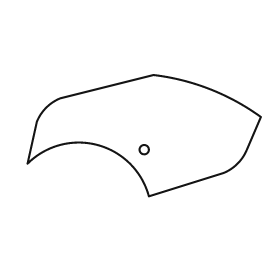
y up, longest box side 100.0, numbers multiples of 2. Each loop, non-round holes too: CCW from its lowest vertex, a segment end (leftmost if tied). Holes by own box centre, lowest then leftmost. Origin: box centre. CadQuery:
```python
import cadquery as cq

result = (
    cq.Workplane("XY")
    .moveTo(2.0, -26.0)
    .lineTo(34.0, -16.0)
    .threePointArc((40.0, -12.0), (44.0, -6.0))
    .lineTo(50.0, 8.0)
    .threePointArc((28.0, 20.0), (4.0, 26.0))
    .lineTo(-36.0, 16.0)
    .threePointArc((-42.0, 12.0), (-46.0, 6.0))
    .lineTo(-50.0, -12.0)
    .threePointArc((-20.0, -4.0), (2.0, -26.0))
    .close()
    .moveTo(0.0, -6.0)
    .circle(2.0)
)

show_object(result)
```